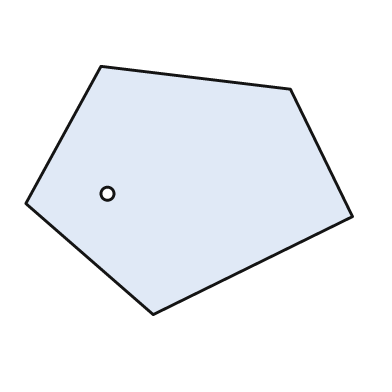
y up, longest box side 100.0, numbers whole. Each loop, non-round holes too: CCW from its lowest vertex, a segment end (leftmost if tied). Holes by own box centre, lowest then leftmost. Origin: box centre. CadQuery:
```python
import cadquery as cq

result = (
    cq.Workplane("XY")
    .moveTo(-11.0, -38.0)
    .lineTo(50.0, -8.0)
    .lineTo(31.0, 31.0)
    .lineTo(-27.0, 38.0)
    .lineTo(-50.0, -4.0)
    .close()
    .moveTo(-25.0, -1.0)
    .circle(2.0)
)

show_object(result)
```